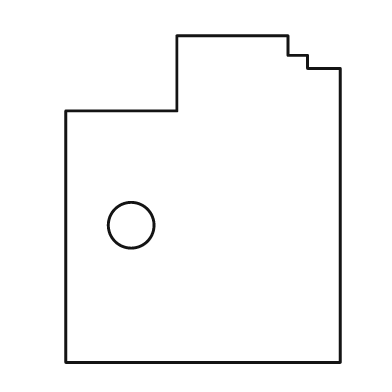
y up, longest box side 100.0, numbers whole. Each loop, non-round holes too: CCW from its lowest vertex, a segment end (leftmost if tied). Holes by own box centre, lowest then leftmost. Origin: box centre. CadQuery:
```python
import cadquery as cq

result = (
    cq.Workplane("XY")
    .moveTo(-42.0, -50.0)
    .lineTo(42.0, -50.0)
    .lineTo(42.0, 40.0)
    .lineTo(32.0, 40.0)
    .lineTo(32.0, 44.0)
    .lineTo(26.0, 44.0)
    .lineTo(26.0, 50.0)
    .lineTo(-8.0, 50.0)
    .lineTo(-8.0, 27.0)
    .lineTo(-42.0, 27.0)
    .close()
    .moveTo(-22.0, -8.0)
    .circle(7.0)
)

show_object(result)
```